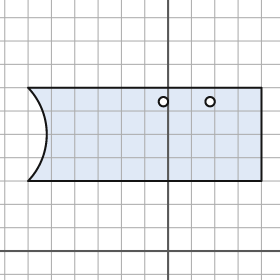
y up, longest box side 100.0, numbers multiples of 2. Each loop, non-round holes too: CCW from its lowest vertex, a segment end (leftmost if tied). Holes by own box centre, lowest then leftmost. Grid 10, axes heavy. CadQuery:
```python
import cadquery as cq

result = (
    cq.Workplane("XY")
    .moveTo(-60.0, 30.0)
    .lineTo(40.0, 30.0)
    .lineTo(40.0, 70.0)
    .lineTo(-60.0, 70.0)
    .threePointArc((-52.0, 50.0), (-60.0, 30.0))
    .close()
    .moveTo(-2.0, 64.0)
    .circle(2.0)
    .moveTo(18.0, 64.0)
    .circle(2.0)
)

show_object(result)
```